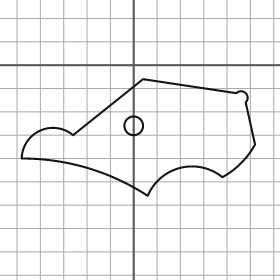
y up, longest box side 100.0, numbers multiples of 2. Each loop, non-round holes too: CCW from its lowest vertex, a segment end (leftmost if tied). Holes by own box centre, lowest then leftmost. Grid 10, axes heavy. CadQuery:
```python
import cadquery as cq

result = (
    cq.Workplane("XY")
    .moveTo(6.0, -56.0)
    .threePointArc((20.0, -44.0), (38.0, -48.0))
    .threePointArc((46.0, -42.0), (52.0, -34.0))
    .lineTo(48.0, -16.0)
    .threePointArc((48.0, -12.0), (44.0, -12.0))
    .lineTo(4.0, -6.0)
    .lineTo(-26.0, -30.0)
    .threePointArc((-40.0, -28.0), (-48.0, -40.0))
    .threePointArc((-20.0, -44.0), (6.0, -56.0))
    .close()
    .moveTo(0.0, -26.0)
    .circle(4.0)
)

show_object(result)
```